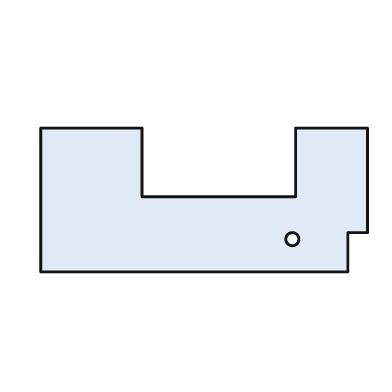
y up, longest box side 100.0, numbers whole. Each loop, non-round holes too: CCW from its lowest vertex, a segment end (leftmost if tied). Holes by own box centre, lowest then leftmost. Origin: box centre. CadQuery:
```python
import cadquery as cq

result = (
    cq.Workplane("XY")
    .moveTo(-50.0, -22.0)
    .lineTo(44.0, -22.0)
    .lineTo(44.0, -10.0)
    .lineTo(50.0, -10.0)
    .lineTo(50.0, 22.0)
    .lineTo(28.0, 22.0)
    .lineTo(28.0, 1.0)
    .lineTo(-19.0, 1.0)
    .lineTo(-19.0, 22.0)
    .lineTo(-50.0, 22.0)
    .close()
    .moveTo(27.0, -12.0)
    .circle(2.0)
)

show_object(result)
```